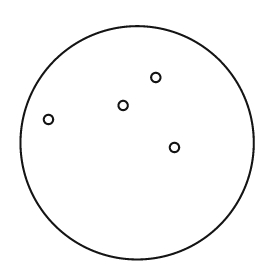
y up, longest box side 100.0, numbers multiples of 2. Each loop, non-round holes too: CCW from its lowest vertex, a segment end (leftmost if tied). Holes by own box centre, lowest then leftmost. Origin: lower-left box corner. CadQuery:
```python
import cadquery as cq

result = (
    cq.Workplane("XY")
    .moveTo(50.0, 50.0)
    .circle(50.0)
    .moveTo(66.0, 48.0)
    .circle(2.0)
    .moveTo(12.0, 60.0)
    .circle(2.0)
    .moveTo(44.0, 66.0)
    .circle(2.0)
    .moveTo(58.0, 78.0)
    .circle(2.0)
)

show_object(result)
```